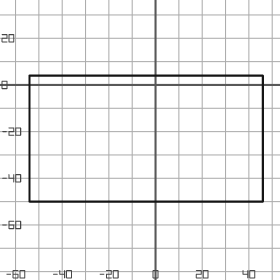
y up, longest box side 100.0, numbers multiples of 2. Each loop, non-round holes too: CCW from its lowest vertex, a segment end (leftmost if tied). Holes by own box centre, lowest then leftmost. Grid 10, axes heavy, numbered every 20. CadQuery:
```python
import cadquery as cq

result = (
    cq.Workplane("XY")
    .moveTo(-54.0, -50.0)
    .lineTo(46.0, -50.0)
    .lineTo(46.0, 4.0)
    .lineTo(-54.0, 4.0)
    .close()
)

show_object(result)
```